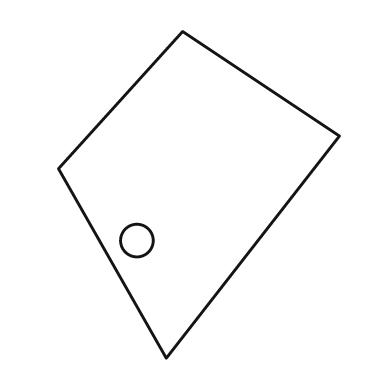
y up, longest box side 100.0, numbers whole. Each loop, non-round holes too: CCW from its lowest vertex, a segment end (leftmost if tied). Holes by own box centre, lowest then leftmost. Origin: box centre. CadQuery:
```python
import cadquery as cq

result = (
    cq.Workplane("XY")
    .moveTo(-10.0, -50.0)
    .lineTo(43.0, 18.0)
    .lineTo(-5.0, 50.0)
    .lineTo(-43.0, 8.0)
    .close()
    .moveTo(-19.0, -14.0)
    .circle(5.0)
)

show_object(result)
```